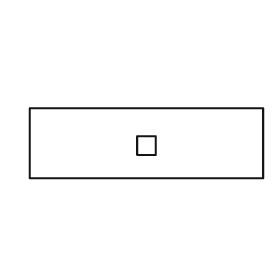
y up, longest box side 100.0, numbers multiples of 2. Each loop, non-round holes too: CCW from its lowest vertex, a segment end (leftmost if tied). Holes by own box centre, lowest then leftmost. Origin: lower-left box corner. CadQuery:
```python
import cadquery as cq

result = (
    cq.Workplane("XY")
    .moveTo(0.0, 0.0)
    .lineTo(100.0, 0.0)
    .lineTo(100.0, 30.0)
    .lineTo(0.0, 30.0)
    .close()
    .moveTo(46.0, 10.0)
    .lineTo(54.0, 10.0)
    .lineTo(54.0, 18.0)
    .lineTo(46.0, 18.0)
    .close()
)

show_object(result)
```